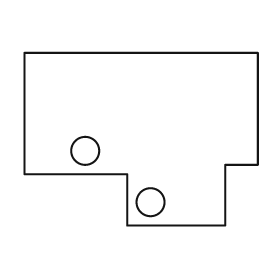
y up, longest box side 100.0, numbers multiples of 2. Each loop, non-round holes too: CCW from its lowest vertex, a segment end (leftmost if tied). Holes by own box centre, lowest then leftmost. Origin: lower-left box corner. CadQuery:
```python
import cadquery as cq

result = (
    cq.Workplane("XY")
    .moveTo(44.0, 0.0)
    .lineTo(86.0, 0.0)
    .lineTo(86.0, 26.0)
    .lineTo(100.0, 26.0)
    .lineTo(100.0, 74.0)
    .lineTo(0.0, 74.0)
    .lineTo(0.0, 22.0)
    .lineTo(44.0, 22.0)
    .close()
    .moveTo(54.0, 10.0)
    .circle(6.0)
    .moveTo(26.0, 32.0)
    .circle(6.0)
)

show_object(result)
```